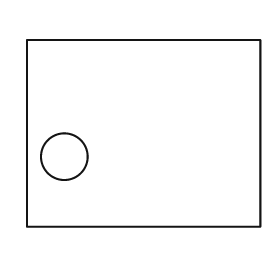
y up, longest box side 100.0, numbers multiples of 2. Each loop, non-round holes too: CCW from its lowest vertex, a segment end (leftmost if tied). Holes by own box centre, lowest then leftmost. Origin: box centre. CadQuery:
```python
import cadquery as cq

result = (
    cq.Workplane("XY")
    .moveTo(-50.0, -40.0)
    .lineTo(50.0, -40.0)
    .lineTo(50.0, 40.0)
    .lineTo(-50.0, 40.0)
    .close()
    .moveTo(-34.0, -10.0)
    .circle(10.0)
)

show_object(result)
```